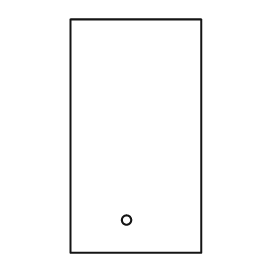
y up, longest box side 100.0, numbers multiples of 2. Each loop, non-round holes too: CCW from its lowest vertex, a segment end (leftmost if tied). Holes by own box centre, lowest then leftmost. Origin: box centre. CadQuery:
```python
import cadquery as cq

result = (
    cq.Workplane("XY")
    .moveTo(-28.0, -50.0)
    .lineTo(28.0, -50.0)
    .lineTo(28.0, 50.0)
    .lineTo(-28.0, 50.0)
    .close()
    .moveTo(-4.0, -36.0)
    .circle(2.0)
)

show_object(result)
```